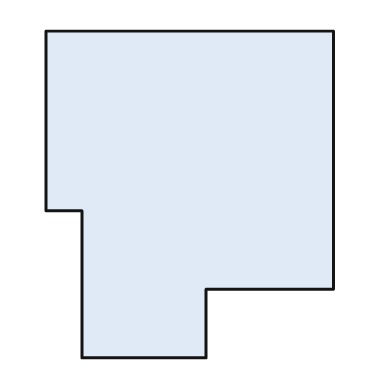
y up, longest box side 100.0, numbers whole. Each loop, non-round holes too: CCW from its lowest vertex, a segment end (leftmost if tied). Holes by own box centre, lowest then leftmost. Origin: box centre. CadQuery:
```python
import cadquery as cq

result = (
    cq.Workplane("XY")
    .moveTo(-33.0, -50.0)
    .lineTo(5.0, -50.0)
    .lineTo(5.0, -29.0)
    .lineTo(44.0, -29.0)
    .lineTo(44.0, 50.0)
    .lineTo(-44.0, 50.0)
    .lineTo(-44.0, -5.0)
    .lineTo(-33.0, -5.0)
    .close()
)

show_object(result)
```